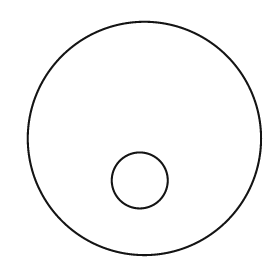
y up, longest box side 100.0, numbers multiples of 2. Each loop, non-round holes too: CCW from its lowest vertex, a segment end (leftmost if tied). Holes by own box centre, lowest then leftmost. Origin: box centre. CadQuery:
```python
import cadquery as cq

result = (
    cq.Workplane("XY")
    .moveTo(0.0, 0.0)
    .circle(50.0)
    .moveTo(-2.0, -18.0)
    .circle(12.0)
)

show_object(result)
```